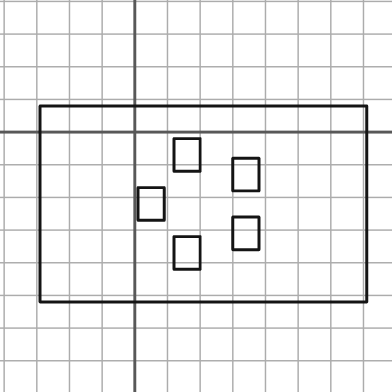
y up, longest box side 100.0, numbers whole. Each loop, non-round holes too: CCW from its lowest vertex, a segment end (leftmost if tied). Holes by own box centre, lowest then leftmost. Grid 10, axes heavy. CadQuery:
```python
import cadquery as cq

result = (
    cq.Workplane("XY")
    .moveTo(-29.0, -52.0)
    .lineTo(71.0, -52.0)
    .lineTo(71.0, 8.0)
    .lineTo(-29.0, 8.0)
    .close()
    .moveTo(12.0, -42.0)
    .lineTo(20.0, -42.0)
    .lineTo(20.0, -32.0)
    .lineTo(12.0, -32.0)
    .close()
    .moveTo(30.0, -36.0)
    .lineTo(38.0, -36.0)
    .lineTo(38.0, -26.0)
    .lineTo(30.0, -26.0)
    .close()
    .moveTo(1.0, -27.0)
    .lineTo(9.0, -27.0)
    .lineTo(9.0, -17.0)
    .lineTo(1.0, -17.0)
    .close()
    .moveTo(30.0, -18.0)
    .lineTo(38.0, -18.0)
    .lineTo(38.0, -8.0)
    .lineTo(30.0, -8.0)
    .close()
    .moveTo(12.0, -12.0)
    .lineTo(20.0, -12.0)
    .lineTo(20.0, -2.0)
    .lineTo(12.0, -2.0)
    .close()
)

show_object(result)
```